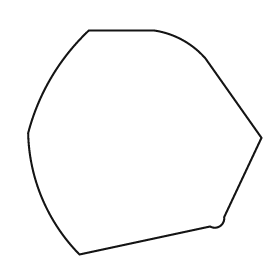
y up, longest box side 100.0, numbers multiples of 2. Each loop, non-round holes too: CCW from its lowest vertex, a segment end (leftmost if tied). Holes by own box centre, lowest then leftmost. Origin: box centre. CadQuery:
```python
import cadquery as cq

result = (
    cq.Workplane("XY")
    .moveTo(-28.0, -48.0)
    .lineTo(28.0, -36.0)
    .threePointArc((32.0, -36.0), (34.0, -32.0))
    .lineTo(50.0, 2.0)
    .lineTo(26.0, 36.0)
    .threePointArc((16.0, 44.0), (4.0, 48.0))
    .lineTo(-24.0, 48.0)
    .threePointArc((-40.0, 28.0), (-50.0, 4.0))
    .threePointArc((-44.0, -24.0), (-28.0, -48.0))
    .close()
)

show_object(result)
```